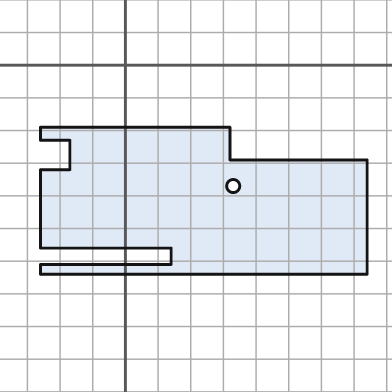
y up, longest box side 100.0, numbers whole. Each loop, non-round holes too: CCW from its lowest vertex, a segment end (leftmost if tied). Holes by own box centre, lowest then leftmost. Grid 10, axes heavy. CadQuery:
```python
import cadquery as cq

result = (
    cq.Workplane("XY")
    .moveTo(-26.0, -64.0)
    .lineTo(74.0, -64.0)
    .lineTo(74.0, -29.0)
    .lineTo(32.0, -29.0)
    .lineTo(32.0, -19.0)
    .lineTo(-26.0, -19.0)
    .lineTo(-26.0, -23.0)
    .lineTo(-17.0, -23.0)
    .lineTo(-17.0, -32.0)
    .lineTo(-26.0, -32.0)
    .lineTo(-26.0, -56.0)
    .lineTo(14.0, -56.0)
    .lineTo(14.0, -61.0)
    .lineTo(-26.0, -61.0)
    .close()
    .moveTo(33.0, -37.0)
    .circle(2.0)
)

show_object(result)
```